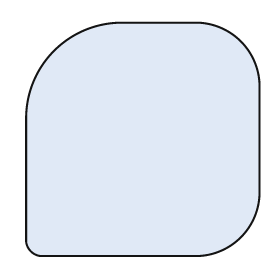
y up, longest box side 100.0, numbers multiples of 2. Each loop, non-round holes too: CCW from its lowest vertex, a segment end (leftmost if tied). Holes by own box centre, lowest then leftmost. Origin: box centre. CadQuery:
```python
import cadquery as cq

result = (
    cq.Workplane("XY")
    .moveTo(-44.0, -50.0)
    .lineTo(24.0, -50.0)
    .threePointArc((42.0, -42.0), (50.0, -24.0))
    .lineTo(50.0, 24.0)
    .threePointArc((42.0, 42.0), (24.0, 50.0))
    .lineTo(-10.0, 50.0)
    .threePointArc((-38.0, 38.0), (-50.0, 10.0))
    .lineTo(-50.0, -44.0)
    .threePointArc((-48.0, -48.0), (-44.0, -50.0))
    .close()
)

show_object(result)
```